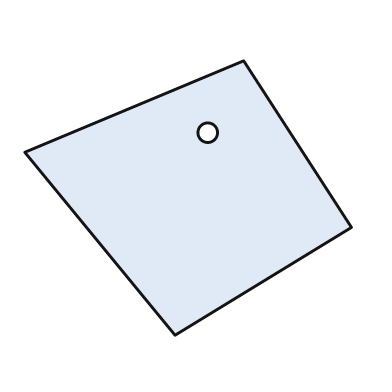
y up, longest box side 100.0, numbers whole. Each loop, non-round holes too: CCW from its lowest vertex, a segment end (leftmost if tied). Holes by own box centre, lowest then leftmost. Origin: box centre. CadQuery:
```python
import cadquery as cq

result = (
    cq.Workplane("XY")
    .moveTo(-4.0, -42.0)
    .lineTo(50.0, -9.0)
    .lineTo(17.0, 42.0)
    .lineTo(-50.0, 14.0)
    .close()
    .moveTo(6.0, 20.0)
    .circle(3.0)
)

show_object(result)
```